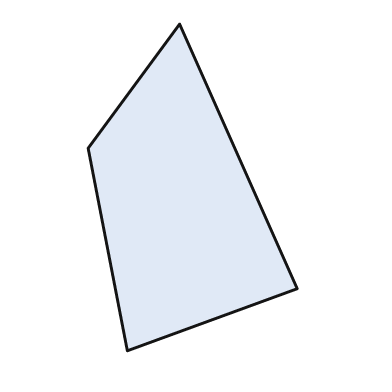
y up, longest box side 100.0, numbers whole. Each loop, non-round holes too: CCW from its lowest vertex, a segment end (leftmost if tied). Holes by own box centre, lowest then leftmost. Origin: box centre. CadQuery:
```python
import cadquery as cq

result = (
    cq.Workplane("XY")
    .moveTo(-20.0, -50.0)
    .lineTo(32.0, -31.0)
    .lineTo(-4.0, 50.0)
    .lineTo(-32.0, 12.0)
    .close()
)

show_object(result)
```